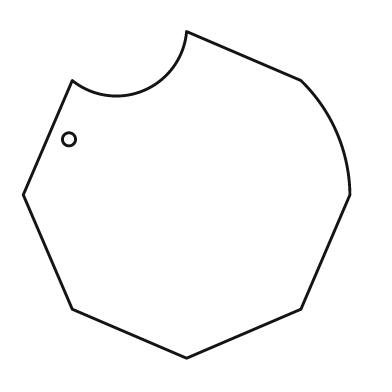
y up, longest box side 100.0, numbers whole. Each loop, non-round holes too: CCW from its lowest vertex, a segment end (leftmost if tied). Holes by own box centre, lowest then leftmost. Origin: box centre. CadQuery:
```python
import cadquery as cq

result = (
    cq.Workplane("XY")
    .moveTo(0.0, -50.0)
    .lineTo(35.0, -35.0)
    .lineTo(50.0, 0.0)
    .threePointArc((46.0, 19.0), (35.0, 35.0))
    .lineTo(0.0, 50.0)
    .threePointArc((-13.0, 32.0), (-35.0, 35.0))
    .lineTo(-50.0, 0.0)
    .lineTo(-35.0, -35.0)
    .close()
    .moveTo(-36.0, 17.0)
    .circle(2.0)
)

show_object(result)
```